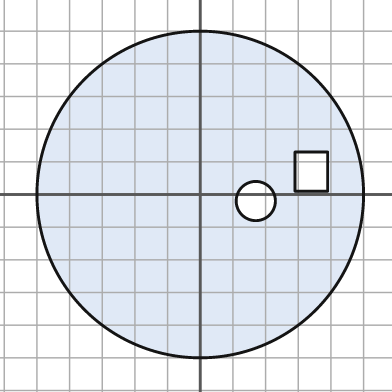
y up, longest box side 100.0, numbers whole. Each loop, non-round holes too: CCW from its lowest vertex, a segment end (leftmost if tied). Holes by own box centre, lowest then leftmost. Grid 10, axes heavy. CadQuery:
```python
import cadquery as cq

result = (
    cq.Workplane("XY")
    .moveTo(0.0, 0.0)
    .circle(50.0)
    .moveTo(17.0, -2.0)
    .circle(6.0)
    .moveTo(29.0, 1.0)
    .lineTo(39.0, 1.0)
    .lineTo(39.0, 13.0)
    .lineTo(29.0, 13.0)
    .close()
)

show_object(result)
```